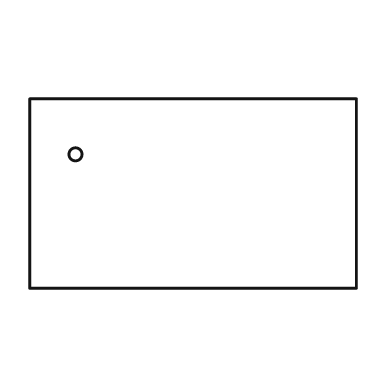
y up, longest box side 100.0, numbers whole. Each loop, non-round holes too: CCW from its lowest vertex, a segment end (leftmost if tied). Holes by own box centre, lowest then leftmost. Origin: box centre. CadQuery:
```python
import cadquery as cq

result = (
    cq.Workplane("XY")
    .moveTo(-50.0, -29.0)
    .lineTo(50.0, -29.0)
    .lineTo(50.0, 29.0)
    .lineTo(-50.0, 29.0)
    .close()
    .moveTo(-36.0, 12.0)
    .circle(2.0)
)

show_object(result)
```